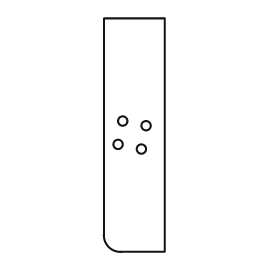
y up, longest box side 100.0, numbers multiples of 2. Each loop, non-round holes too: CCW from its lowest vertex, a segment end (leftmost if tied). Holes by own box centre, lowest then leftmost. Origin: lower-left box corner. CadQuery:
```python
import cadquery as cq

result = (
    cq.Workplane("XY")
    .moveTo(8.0, 0.0)
    .lineTo(26.0, 0.0)
    .lineTo(26.0, 100.0)
    .lineTo(0.0, 100.0)
    .lineTo(0.0, 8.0)
    .threePointArc((2.0, 2.0), (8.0, 0.0))
    .close()
    .moveTo(16.0, 44.0)
    .circle(2.0)
    .moveTo(6.0, 46.0)
    .circle(2.0)
    .moveTo(18.0, 54.0)
    .circle(2.0)
    .moveTo(8.0, 56.0)
    .circle(2.0)
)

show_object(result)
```